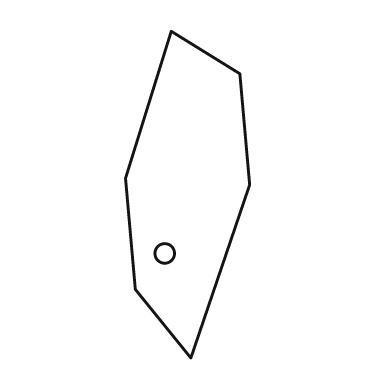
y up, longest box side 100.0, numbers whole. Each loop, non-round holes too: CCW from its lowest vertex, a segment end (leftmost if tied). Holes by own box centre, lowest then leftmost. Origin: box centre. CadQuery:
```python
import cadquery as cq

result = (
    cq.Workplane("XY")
    .moveTo(1.0, -50.0)
    .lineTo(19.0, 3.0)
    .lineTo(16.0, 37.0)
    .lineTo(-5.0, 50.0)
    .lineTo(-19.0, 5.0)
    .lineTo(-16.0, -29.0)
    .close()
    .moveTo(-7.0, -18.0)
    .circle(3.0)
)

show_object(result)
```